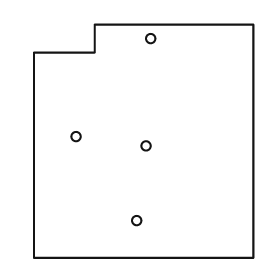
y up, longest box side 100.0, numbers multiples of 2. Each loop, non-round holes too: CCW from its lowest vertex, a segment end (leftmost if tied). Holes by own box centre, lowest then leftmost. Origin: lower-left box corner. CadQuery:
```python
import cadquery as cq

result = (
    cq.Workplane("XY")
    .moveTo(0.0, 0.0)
    .lineTo(94.0, 0.0)
    .lineTo(94.0, 100.0)
    .lineTo(26.0, 100.0)
    .lineTo(26.0, 88.0)
    .lineTo(0.0, 88.0)
    .close()
    .moveTo(44.0, 16.0)
    .circle(2.0)
    .moveTo(48.0, 48.0)
    .circle(2.0)
    .moveTo(18.0, 52.0)
    .circle(2.0)
    .moveTo(50.0, 94.0)
    .circle(2.0)
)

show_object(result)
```